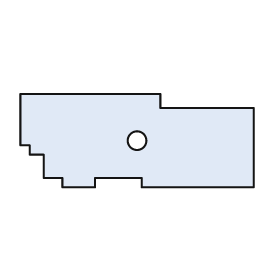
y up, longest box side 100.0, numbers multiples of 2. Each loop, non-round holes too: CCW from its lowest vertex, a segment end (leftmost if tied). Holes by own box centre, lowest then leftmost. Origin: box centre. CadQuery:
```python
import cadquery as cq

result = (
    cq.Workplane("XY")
    .moveTo(-32.0, -20.0)
    .lineTo(-18.0, -20.0)
    .lineTo(-18.0, -16.0)
    .lineTo(2.0, -16.0)
    .lineTo(2.0, -20.0)
    .lineTo(50.0, -20.0)
    .lineTo(50.0, 14.0)
    .lineTo(10.0, 14.0)
    .lineTo(10.0, 20.0)
    .lineTo(-50.0, 20.0)
    .lineTo(-50.0, -2.0)
    .lineTo(-46.0, -2.0)
    .lineTo(-46.0, -6.0)
    .lineTo(-40.0, -6.0)
    .lineTo(-40.0, -16.0)
    .lineTo(-32.0, -16.0)
    .close()
    .moveTo(0.0, 0.0)
    .circle(4.0)
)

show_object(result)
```